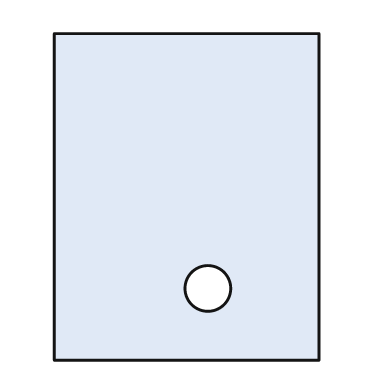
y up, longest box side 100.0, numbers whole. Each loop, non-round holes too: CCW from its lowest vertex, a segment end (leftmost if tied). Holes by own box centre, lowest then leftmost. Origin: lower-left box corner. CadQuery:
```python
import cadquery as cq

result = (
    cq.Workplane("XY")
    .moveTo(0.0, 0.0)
    .lineTo(81.0, 0.0)
    .lineTo(81.0, 100.0)
    .lineTo(0.0, 100.0)
    .close()
    .moveTo(47.0, 22.0)
    .circle(7.0)
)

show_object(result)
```